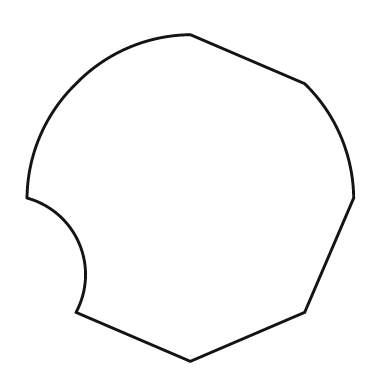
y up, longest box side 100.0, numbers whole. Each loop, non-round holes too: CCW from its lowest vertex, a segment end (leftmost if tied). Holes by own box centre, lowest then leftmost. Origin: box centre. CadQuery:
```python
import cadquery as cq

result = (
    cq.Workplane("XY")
    .moveTo(0.0, -50.0)
    .lineTo(35.0, -35.0)
    .lineTo(50.0, 0.0)
    .threePointArc((46.0, 19.0), (35.0, 35.0))
    .lineTo(0.0, 50.0)
    .threePointArc((-19.0, 46.0), (-35.0, 35.0))
    .threePointArc((-46.0, 19.0), (-50.0, 0.0))
    .threePointArc((-34.0, -14.0), (-35.0, -35.0))
    .close()
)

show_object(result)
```